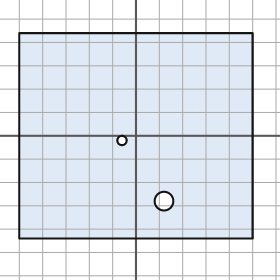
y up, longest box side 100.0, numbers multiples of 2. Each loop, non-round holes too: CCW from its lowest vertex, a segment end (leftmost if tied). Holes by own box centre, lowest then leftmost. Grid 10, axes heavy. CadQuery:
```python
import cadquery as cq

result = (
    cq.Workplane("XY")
    .moveTo(-50.0, -44.0)
    .lineTo(50.0, -44.0)
    .lineTo(50.0, 44.0)
    .lineTo(-50.0, 44.0)
    .close()
    .moveTo(12.0, -28.0)
    .circle(4.0)
    .moveTo(-6.0, -2.0)
    .circle(2.0)
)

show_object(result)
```